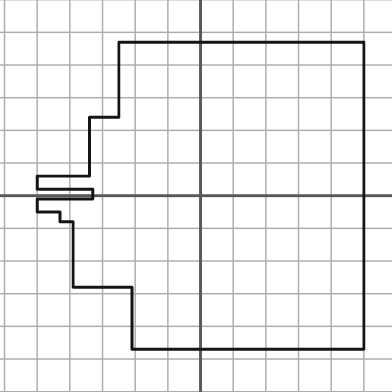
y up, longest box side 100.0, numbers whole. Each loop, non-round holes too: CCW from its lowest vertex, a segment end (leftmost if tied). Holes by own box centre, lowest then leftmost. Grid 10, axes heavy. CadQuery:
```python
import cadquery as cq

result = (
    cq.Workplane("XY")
    .moveTo(-21.0, -47.0)
    .lineTo(50.0, -47.0)
    .lineTo(50.0, 47.0)
    .lineTo(-25.0, 47.0)
    .lineTo(-25.0, 24.0)
    .lineTo(-34.0, 24.0)
    .lineTo(-34.0, 6.0)
    .lineTo(-50.0, 6.0)
    .lineTo(-50.0, 2.0)
    .lineTo(-33.0, 2.0)
    .lineTo(-33.0, -1.0)
    .lineTo(-50.0, -1.0)
    .lineTo(-50.0, -5.0)
    .lineTo(-43.0, -5.0)
    .lineTo(-43.0, -8.0)
    .lineTo(-39.0, -8.0)
    .lineTo(-39.0, -28.0)
    .lineTo(-21.0, -28.0)
    .close()
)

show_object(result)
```